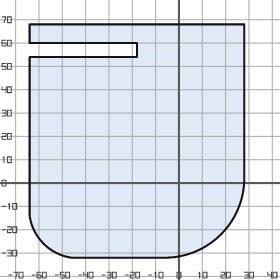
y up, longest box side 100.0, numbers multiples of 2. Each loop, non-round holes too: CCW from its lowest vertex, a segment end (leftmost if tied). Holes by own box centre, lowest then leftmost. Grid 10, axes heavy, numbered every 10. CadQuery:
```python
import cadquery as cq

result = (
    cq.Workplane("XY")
    .moveTo(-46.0, -32.0)
    .lineTo(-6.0, -32.0)
    .threePointArc((18.0, -22.0), (28.0, 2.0))
    .lineTo(28.0, 68.0)
    .lineTo(-64.0, 68.0)
    .lineTo(-64.0, 60.0)
    .lineTo(-18.0, 60.0)
    .lineTo(-18.0, 54.0)
    .lineTo(-64.0, 54.0)
    .lineTo(-64.0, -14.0)
    .threePointArc((-58.0, -26.0), (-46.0, -32.0))
    .close()
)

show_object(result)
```